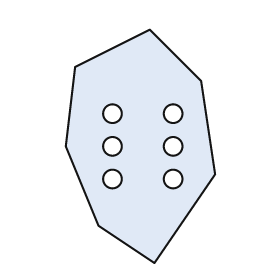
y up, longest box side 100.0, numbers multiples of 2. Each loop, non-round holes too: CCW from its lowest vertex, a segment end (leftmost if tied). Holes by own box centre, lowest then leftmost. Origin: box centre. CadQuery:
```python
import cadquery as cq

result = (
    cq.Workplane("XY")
    .moveTo(6.0, -50.0)
    .lineTo(32.0, -12.0)
    .lineTo(26.0, 28.0)
    .lineTo(4.0, 50.0)
    .lineTo(-28.0, 34.0)
    .lineTo(-32.0, 0.0)
    .lineTo(-18.0, -34.0)
    .close()
    .moveTo(-12.0, -14.0)
    .circle(4.0)
    .moveTo(14.0, -14.0)
    .circle(4.0)
    .moveTo(-12.0, 0.0)
    .circle(4.0)
    .moveTo(14.0, 0.0)
    .circle(4.0)
    .moveTo(-12.0, 14.0)
    .circle(4.0)
    .moveTo(14.0, 14.0)
    .circle(4.0)
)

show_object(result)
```